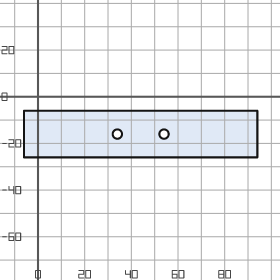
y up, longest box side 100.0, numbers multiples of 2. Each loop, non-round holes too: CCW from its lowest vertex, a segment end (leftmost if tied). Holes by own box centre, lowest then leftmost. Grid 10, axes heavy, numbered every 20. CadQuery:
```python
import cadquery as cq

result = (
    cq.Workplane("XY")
    .moveTo(-6.0, -26.0)
    .lineTo(94.0, -26.0)
    .lineTo(94.0, -6.0)
    .lineTo(-6.0, -6.0)
    .close()
    .moveTo(34.0, -16.0)
    .circle(2.0)
    .moveTo(54.0, -16.0)
    .circle(2.0)
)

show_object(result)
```